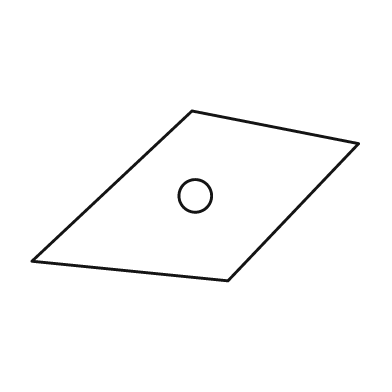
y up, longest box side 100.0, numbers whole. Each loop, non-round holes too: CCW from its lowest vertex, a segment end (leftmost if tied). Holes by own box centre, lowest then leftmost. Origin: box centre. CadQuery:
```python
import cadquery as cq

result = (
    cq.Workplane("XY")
    .moveTo(10.0, -26.0)
    .lineTo(50.0, 16.0)
    .lineTo(-1.0, 26.0)
    .lineTo(-50.0, -20.0)
    .close()
    .moveTo(0.0, 0.0)
    .circle(5.0)
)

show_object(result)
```